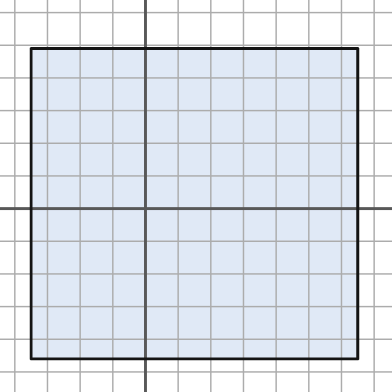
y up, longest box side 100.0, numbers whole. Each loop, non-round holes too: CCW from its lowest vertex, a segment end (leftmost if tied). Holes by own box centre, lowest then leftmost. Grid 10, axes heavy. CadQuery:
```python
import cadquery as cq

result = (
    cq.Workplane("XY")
    .moveTo(-35.0, -46.0)
    .lineTo(65.0, -46.0)
    .lineTo(65.0, 49.0)
    .lineTo(-35.0, 49.0)
    .close()
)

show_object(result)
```